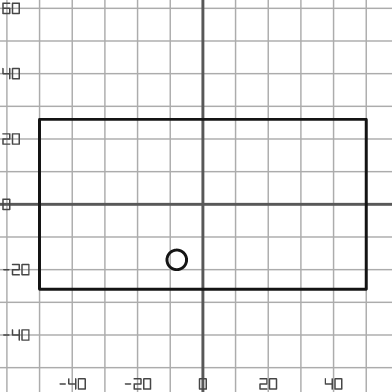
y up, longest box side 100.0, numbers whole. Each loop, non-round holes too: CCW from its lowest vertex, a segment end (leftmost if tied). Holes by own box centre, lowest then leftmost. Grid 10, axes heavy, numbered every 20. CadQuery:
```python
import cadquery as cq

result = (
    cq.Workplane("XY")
    .moveTo(-50.0, -26.0)
    .lineTo(50.0, -26.0)
    .lineTo(50.0, 26.0)
    .lineTo(-50.0, 26.0)
    .close()
    .moveTo(-8.0, -17.0)
    .circle(3.0)
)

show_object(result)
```